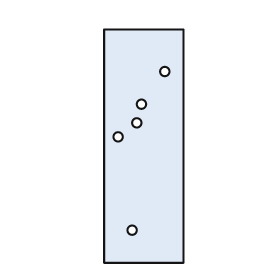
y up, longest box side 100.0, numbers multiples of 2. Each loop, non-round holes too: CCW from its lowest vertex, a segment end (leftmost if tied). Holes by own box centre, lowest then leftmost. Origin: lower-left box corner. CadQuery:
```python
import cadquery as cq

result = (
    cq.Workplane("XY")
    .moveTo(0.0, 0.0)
    .lineTo(34.0, 0.0)
    .lineTo(34.0, 100.0)
    .lineTo(0.0, 100.0)
    .close()
    .moveTo(12.0, 14.0)
    .circle(2.0)
    .moveTo(6.0, 54.0)
    .circle(2.0)
    .moveTo(14.0, 60.0)
    .circle(2.0)
    .moveTo(16.0, 68.0)
    .circle(2.0)
    .moveTo(26.0, 82.0)
    .circle(2.0)
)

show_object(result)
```